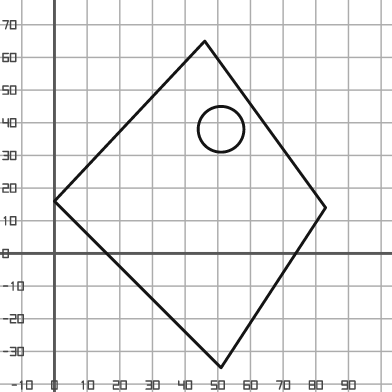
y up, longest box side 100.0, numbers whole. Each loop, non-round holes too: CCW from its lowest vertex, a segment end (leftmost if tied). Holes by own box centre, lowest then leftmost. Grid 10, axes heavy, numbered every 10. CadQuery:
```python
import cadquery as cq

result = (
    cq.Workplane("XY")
    .moveTo(51.0, -35.0)
    .lineTo(83.0, 14.0)
    .lineTo(46.0, 65.0)
    .lineTo(0.0, 16.0)
    .close()
    .moveTo(51.0, 38.0)
    .circle(7.0)
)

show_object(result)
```